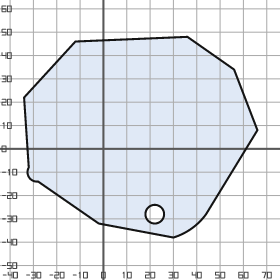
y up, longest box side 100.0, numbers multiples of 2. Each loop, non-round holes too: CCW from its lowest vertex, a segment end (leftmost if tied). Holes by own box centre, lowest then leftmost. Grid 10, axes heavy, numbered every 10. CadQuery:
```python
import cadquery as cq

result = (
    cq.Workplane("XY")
    .moveTo(30.0, -38.0)
    .threePointArc((38.0, -34.0), (44.0, -28.0))
    .lineTo(66.0, 8.0)
    .lineTo(56.0, 34.0)
    .lineTo(36.0, 48.0)
    .lineTo(-12.0, 46.0)
    .lineTo(-34.0, 22.0)
    .lineTo(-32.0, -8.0)
    .threePointArc((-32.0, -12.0), (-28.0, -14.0))
    .lineTo(-2.0, -32.0)
    .close()
    .moveTo(22.0, -28.0)
    .circle(4.0)
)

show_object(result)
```